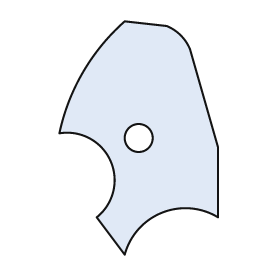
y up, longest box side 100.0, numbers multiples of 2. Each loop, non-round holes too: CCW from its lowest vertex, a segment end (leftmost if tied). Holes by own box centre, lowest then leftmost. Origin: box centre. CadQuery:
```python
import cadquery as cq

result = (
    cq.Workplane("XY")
    .moveTo(-6.0, -50.0)
    .threePointArc((10.0, -32.0), (34.0, -34.0))
    .lineTo(34.0, -4.0)
    .lineTo(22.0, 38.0)
    .threePointArc((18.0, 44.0), (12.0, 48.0))
    .lineTo(-6.0, 50.0)
    .threePointArc((-24.0, 28.0), (-34.0, 2.0))
    .threePointArc((-12.0, -10.0), (-18.0, -34.0))
    .close()
    .moveTo(0.0, 0.0)
    .circle(6.0)
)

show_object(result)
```